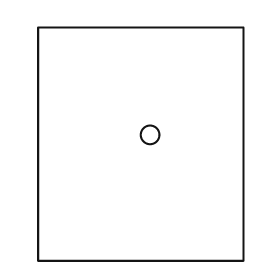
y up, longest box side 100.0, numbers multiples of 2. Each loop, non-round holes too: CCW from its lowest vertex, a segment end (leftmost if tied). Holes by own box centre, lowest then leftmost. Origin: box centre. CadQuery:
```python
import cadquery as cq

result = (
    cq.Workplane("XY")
    .moveTo(-44.0, -50.0)
    .lineTo(44.0, -50.0)
    .lineTo(44.0, 50.0)
    .lineTo(-44.0, 50.0)
    .close()
    .moveTo(4.0, 4.0)
    .circle(4.0)
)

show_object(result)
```